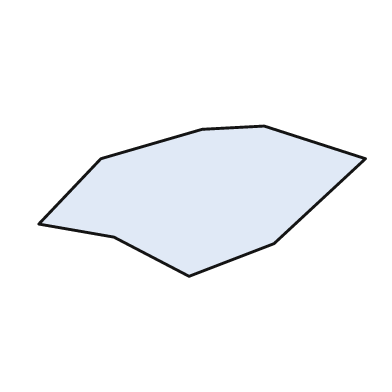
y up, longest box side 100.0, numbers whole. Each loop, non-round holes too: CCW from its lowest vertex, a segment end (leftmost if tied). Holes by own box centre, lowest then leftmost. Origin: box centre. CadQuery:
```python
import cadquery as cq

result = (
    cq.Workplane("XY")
    .moveTo(-4.0, -23.0)
    .lineTo(22.0, -13.0)
    .lineTo(50.0, 13.0)
    .lineTo(19.0, 23.0)
    .lineTo(0.0, 22.0)
    .lineTo(-31.0, 13.0)
    .lineTo(-50.0, -7.0)
    .lineTo(-27.0, -11.0)
    .close()
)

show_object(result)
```